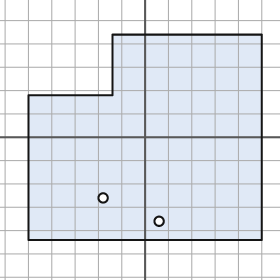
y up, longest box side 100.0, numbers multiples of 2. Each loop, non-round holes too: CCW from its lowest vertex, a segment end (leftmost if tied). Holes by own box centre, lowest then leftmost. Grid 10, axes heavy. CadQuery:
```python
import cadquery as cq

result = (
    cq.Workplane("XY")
    .moveTo(-50.0, -44.0)
    .lineTo(50.0, -44.0)
    .lineTo(50.0, 44.0)
    .lineTo(-14.0, 44.0)
    .lineTo(-14.0, 18.0)
    .lineTo(-50.0, 18.0)
    .close()
    .moveTo(6.0, -36.0)
    .circle(2.0)
    .moveTo(-18.0, -26.0)
    .circle(2.0)
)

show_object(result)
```